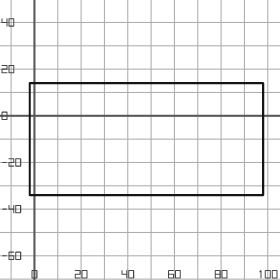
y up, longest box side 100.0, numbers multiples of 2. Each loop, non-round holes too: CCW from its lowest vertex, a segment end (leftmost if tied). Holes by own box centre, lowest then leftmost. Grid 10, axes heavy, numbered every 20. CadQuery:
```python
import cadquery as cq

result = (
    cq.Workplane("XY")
    .moveTo(-2.0, -34.0)
    .lineTo(98.0, -34.0)
    .lineTo(98.0, 14.0)
    .lineTo(-2.0, 14.0)
    .close()
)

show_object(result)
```